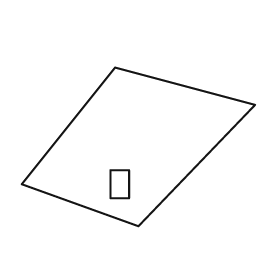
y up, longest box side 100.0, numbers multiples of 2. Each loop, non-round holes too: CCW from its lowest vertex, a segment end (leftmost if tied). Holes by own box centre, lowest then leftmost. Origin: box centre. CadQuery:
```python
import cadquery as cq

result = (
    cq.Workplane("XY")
    .moveTo(0.0, -34.0)
    .lineTo(50.0, 18.0)
    .lineTo(-10.0, 34.0)
    .lineTo(-50.0, -16.0)
    .close()
    .moveTo(-12.0, -22.0)
    .lineTo(-4.0, -22.0)
    .lineTo(-4.0, -10.0)
    .lineTo(-12.0, -10.0)
    .close()
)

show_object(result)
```